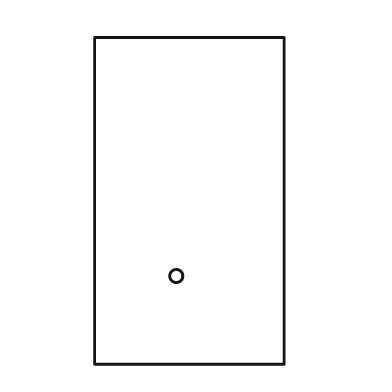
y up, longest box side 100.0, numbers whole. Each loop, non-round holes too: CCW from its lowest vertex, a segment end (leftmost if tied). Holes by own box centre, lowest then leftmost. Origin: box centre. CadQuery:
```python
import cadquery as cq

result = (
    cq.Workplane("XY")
    .moveTo(-29.0, -50.0)
    .lineTo(29.0, -50.0)
    .lineTo(29.0, 50.0)
    .lineTo(-29.0, 50.0)
    .close()
    .moveTo(-4.0, -23.0)
    .circle(2.0)
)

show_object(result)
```